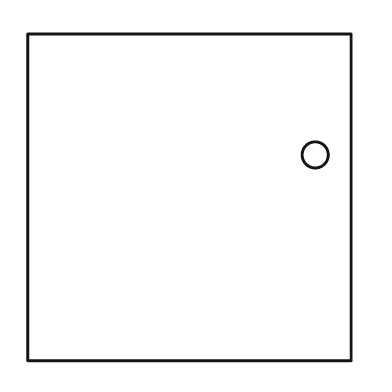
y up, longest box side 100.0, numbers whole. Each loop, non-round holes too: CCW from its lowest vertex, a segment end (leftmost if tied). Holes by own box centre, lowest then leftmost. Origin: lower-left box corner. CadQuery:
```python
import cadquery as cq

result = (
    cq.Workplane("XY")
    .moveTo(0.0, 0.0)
    .lineTo(99.0, 0.0)
    .lineTo(99.0, 100.0)
    .lineTo(0.0, 100.0)
    .close()
    .moveTo(88.0, 63.0)
    .circle(4.0)
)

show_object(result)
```